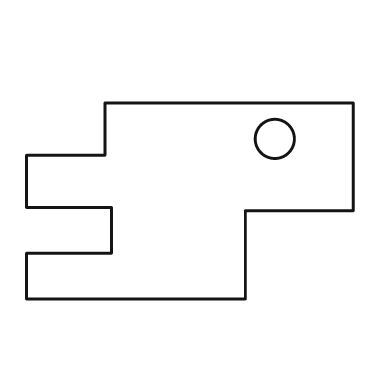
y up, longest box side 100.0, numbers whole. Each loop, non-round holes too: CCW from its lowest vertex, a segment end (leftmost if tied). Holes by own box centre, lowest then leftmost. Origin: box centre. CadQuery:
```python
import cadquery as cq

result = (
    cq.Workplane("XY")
    .moveTo(-50.0, -30.0)
    .lineTo(17.0, -30.0)
    .lineTo(17.0, -3.0)
    .lineTo(50.0, -3.0)
    .lineTo(50.0, 30.0)
    .lineTo(-26.0, 30.0)
    .lineTo(-26.0, 14.0)
    .lineTo(-50.0, 14.0)
    .lineTo(-50.0, -2.0)
    .lineTo(-24.0, -2.0)
    .lineTo(-24.0, -16.0)
    .lineTo(-50.0, -16.0)
    .close()
    .moveTo(26.0, 19.0)
    .circle(6.0)
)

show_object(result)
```